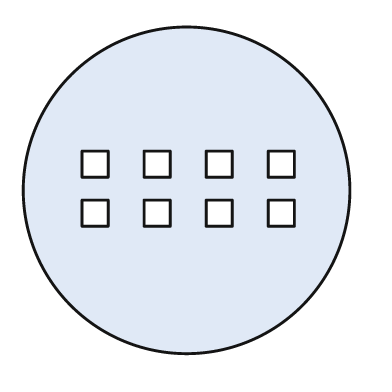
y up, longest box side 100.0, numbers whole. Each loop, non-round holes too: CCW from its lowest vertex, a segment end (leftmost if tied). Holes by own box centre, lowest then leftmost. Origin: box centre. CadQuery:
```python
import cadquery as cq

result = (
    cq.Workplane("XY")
    .moveTo(0.0, 0.0)
    .circle(50.0)
    .moveTo(-32.0, -11.0)
    .lineTo(-24.0, -11.0)
    .lineTo(-24.0, -3.0)
    .lineTo(-32.0, -3.0)
    .close()
    .moveTo(-13.0, -11.0)
    .lineTo(-5.0, -11.0)
    .lineTo(-5.0, -3.0)
    .lineTo(-13.0, -3.0)
    .close()
    .moveTo(6.0, -11.0)
    .lineTo(14.0, -11.0)
    .lineTo(14.0, -3.0)
    .lineTo(6.0, -3.0)
    .close()
    .moveTo(25.0, -11.0)
    .lineTo(33.0, -11.0)
    .lineTo(33.0, -3.0)
    .lineTo(25.0, -3.0)
    .close()
    .moveTo(-32.0, 4.0)
    .lineTo(-24.0, 4.0)
    .lineTo(-24.0, 12.0)
    .lineTo(-32.0, 12.0)
    .close()
    .moveTo(-13.0, 4.0)
    .lineTo(-5.0, 4.0)
    .lineTo(-5.0, 12.0)
    .lineTo(-13.0, 12.0)
    .close()
    .moveTo(6.0, 4.0)
    .lineTo(14.0, 4.0)
    .lineTo(14.0, 12.0)
    .lineTo(6.0, 12.0)
    .close()
    .moveTo(25.0, 4.0)
    .lineTo(33.0, 4.0)
    .lineTo(33.0, 12.0)
    .lineTo(25.0, 12.0)
    .close()
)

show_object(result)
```